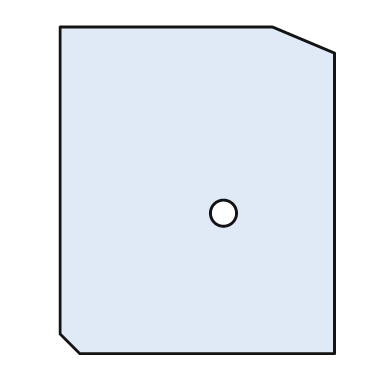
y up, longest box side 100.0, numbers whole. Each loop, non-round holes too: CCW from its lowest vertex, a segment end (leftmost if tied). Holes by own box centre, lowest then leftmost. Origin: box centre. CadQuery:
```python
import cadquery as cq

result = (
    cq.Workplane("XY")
    .moveTo(-36.0, -50.0)
    .lineTo(42.0, -50.0)
    .lineTo(42.0, 42.0)
    .lineTo(23.0, 50.0)
    .lineTo(-42.0, 50.0)
    .lineTo(-42.0, -44.0)
    .close()
    .moveTo(8.0, -7.0)
    .circle(4.0)
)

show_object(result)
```